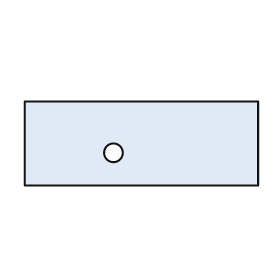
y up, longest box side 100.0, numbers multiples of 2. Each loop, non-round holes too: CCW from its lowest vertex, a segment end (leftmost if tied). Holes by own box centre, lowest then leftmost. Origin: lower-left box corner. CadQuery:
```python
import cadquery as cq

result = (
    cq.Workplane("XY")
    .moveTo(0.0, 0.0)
    .lineTo(100.0, 0.0)
    .lineTo(100.0, 36.0)
    .lineTo(0.0, 36.0)
    .close()
    .moveTo(38.0, 14.0)
    .circle(4.0)
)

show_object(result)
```